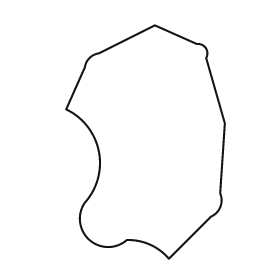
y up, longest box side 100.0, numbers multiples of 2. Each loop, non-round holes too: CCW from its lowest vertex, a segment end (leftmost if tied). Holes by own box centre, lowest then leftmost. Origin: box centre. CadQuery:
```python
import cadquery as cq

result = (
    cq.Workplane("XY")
    .moveTo(10.0, -50.0)
    .lineTo(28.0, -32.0)
    .threePointArc((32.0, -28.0), (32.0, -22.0))
    .lineTo(34.0, 8.0)
    .lineTo(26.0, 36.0)
    .threePointArc((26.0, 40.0), (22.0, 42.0))
    .lineTo(4.0, 50.0)
    .lineTo(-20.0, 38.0)
    .threePointArc((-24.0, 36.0), (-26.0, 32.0))
    .lineTo(-34.0, 14.0)
    .threePointArc((-20.0, -4.0), (-26.0, -26.0))
    .threePointArc((-24.0, -42.0), (-8.0, -42.0))
    .threePointArc((2.0, -44.0), (10.0, -50.0))
    .close()
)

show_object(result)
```